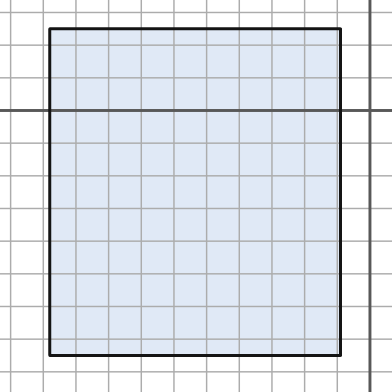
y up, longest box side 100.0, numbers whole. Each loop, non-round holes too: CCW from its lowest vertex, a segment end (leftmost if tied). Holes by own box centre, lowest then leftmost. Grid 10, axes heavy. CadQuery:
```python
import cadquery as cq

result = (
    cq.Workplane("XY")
    .moveTo(-98.0, -75.0)
    .lineTo(-9.0, -75.0)
    .lineTo(-9.0, 25.0)
    .lineTo(-98.0, 25.0)
    .close()
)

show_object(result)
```